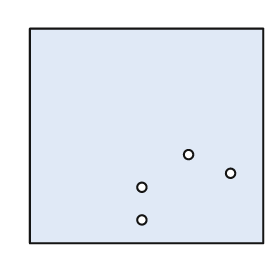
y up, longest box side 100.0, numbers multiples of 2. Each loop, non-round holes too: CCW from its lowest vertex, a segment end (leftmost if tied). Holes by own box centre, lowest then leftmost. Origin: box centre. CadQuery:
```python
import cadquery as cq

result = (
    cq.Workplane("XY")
    .moveTo(-50.0, -46.0)
    .lineTo(50.0, -46.0)
    .lineTo(50.0, 46.0)
    .lineTo(-50.0, 46.0)
    .close()
    .moveTo(-2.0, -36.0)
    .circle(2.0)
    .moveTo(-2.0, -22.0)
    .circle(2.0)
    .moveTo(36.0, -16.0)
    .circle(2.0)
    .moveTo(18.0, -8.0)
    .circle(2.0)
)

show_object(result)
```